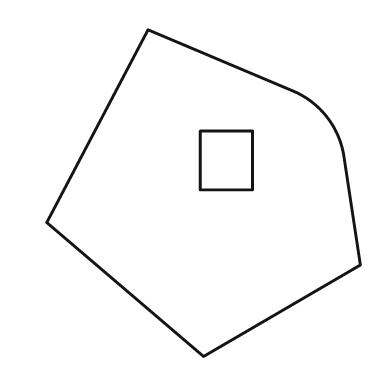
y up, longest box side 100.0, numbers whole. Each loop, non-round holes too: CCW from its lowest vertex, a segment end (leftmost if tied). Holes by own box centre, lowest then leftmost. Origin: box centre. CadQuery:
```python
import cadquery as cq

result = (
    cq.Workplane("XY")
    .moveTo(0.0, -50.0)
    .lineTo(48.0, -22.0)
    .lineTo(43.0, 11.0)
    .threePointArc((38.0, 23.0), (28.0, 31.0))
    .lineTo(-17.0, 50.0)
    .lineTo(-48.0, -9.0)
    .close()
    .moveTo(-1.0, 1.0)
    .lineTo(15.0, 1.0)
    .lineTo(15.0, 19.0)
    .lineTo(-1.0, 19.0)
    .close()
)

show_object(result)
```